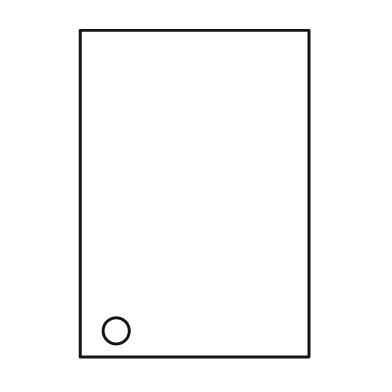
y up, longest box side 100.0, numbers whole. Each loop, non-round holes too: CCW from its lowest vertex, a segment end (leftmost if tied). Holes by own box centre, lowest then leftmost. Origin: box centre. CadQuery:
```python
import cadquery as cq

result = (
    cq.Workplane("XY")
    .moveTo(-35.0, -50.0)
    .lineTo(35.0, -50.0)
    .lineTo(35.0, 50.0)
    .lineTo(-35.0, 50.0)
    .close()
    .moveTo(-24.0, -42.0)
    .circle(4.0)
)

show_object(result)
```